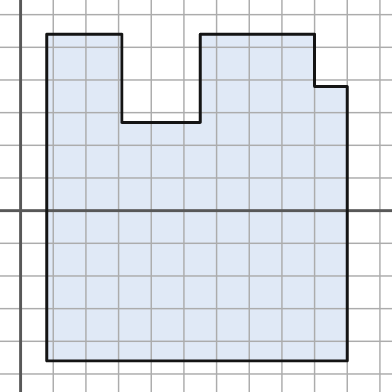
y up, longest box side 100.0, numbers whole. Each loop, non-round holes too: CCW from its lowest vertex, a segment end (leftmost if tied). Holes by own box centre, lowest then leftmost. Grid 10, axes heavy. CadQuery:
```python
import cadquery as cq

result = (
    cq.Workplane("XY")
    .moveTo(8.0, -46.0)
    .lineTo(100.0, -46.0)
    .lineTo(100.0, 38.0)
    .lineTo(90.0, 38.0)
    .lineTo(90.0, 54.0)
    .lineTo(55.0, 54.0)
    .lineTo(55.0, 27.0)
    .lineTo(31.0, 27.0)
    .lineTo(31.0, 54.0)
    .lineTo(8.0, 54.0)
    .close()
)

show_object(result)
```